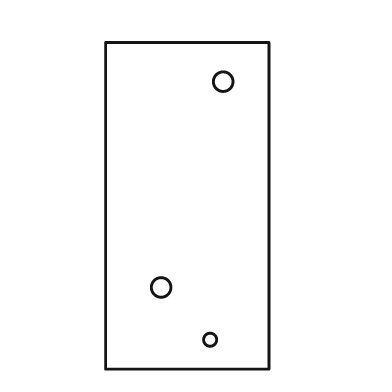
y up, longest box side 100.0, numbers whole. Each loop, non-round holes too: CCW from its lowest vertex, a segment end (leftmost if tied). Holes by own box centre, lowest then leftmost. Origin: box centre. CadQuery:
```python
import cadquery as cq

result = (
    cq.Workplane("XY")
    .moveTo(-25.0, -50.0)
    .lineTo(25.0, -50.0)
    .lineTo(25.0, 50.0)
    .lineTo(-25.0, 50.0)
    .close()
    .moveTo(7.0, -41.0)
    .circle(2.0)
    .moveTo(-8.0, -25.0)
    .circle(3.0)
    .moveTo(11.0, 38.0)
    .circle(3.0)
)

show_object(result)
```